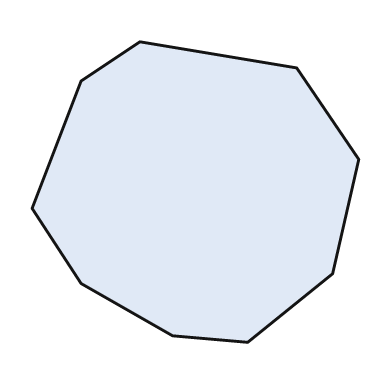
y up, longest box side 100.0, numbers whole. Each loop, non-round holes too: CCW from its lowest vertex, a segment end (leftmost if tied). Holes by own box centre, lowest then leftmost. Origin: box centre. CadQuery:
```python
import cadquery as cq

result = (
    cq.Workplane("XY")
    .moveTo(16.0, -46.0)
    .lineTo(42.0, -25.0)
    .lineTo(50.0, 10.0)
    .lineTo(31.0, 38.0)
    .lineTo(-17.0, 46.0)
    .lineTo(-35.0, 34.0)
    .lineTo(-50.0, -5.0)
    .lineTo(-35.0, -28.0)
    .lineTo(-7.0, -44.0)
    .close()
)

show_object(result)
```